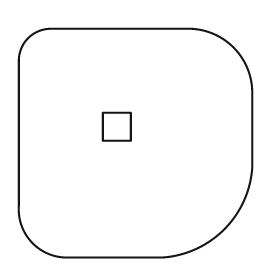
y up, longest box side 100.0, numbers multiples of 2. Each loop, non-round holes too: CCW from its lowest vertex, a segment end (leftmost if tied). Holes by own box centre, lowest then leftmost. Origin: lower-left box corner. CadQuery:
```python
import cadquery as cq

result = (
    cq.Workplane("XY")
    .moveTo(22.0, 0.0)
    .lineTo(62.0, 0.0)
    .threePointArc((88.0, 12.0), (100.0, 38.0))
    .lineTo(100.0, 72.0)
    .threePointArc((92.0, 90.0), (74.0, 98.0))
    .lineTo(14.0, 98.0)
    .threePointArc((4.0, 94.0), (0.0, 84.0))
    .lineTo(0.0, 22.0)
    .threePointArc((6.0, 6.0), (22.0, 0.0))
    .close()
    .moveTo(36.0, 50.0)
    .lineTo(48.0, 50.0)
    .lineTo(48.0, 62.0)
    .lineTo(36.0, 62.0)
    .close()
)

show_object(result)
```